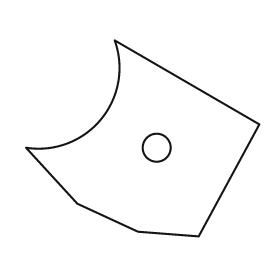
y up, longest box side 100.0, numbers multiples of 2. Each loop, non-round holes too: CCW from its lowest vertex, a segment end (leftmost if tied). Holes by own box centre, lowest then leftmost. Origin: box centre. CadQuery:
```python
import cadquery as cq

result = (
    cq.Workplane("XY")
    .moveTo(24.0, -42.0)
    .lineTo(50.0, 6.0)
    .lineTo(-12.0, 42.0)
    .threePointArc((-18.0, 8.0), (-50.0, -4.0))
    .lineTo(-28.0, -28.0)
    .lineTo(-2.0, -40.0)
    .close()
    .moveTo(6.0, -4.0)
    .circle(6.0)
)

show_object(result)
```